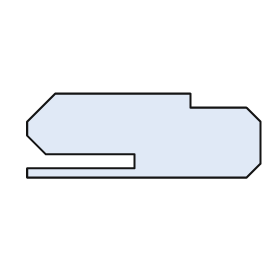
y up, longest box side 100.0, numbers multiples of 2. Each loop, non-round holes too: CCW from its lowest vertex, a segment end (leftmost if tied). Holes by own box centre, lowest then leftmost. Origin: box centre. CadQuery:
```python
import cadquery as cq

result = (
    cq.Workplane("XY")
    .moveTo(-50.0, -18.0)
    .lineTo(44.0, -18.0)
    .lineTo(50.0, -12.0)
    .lineTo(50.0, 6.0)
    .lineTo(44.0, 12.0)
    .lineTo(20.0, 12.0)
    .lineTo(20.0, 18.0)
    .lineTo(-38.0, 18.0)
    .lineTo(-50.0, 6.0)
    .lineTo(-50.0, 0.0)
    .lineTo(-42.0, -8.0)
    .lineTo(-4.0, -8.0)
    .lineTo(-4.0, -14.0)
    .lineTo(-50.0, -14.0)
    .close()
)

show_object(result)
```